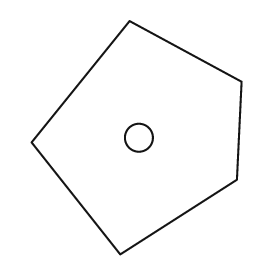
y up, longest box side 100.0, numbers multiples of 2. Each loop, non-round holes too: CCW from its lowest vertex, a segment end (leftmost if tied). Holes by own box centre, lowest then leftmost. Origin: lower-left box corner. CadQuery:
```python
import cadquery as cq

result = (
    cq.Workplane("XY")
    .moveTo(38.0, 0.0)
    .lineTo(88.0, 32.0)
    .lineTo(90.0, 74.0)
    .lineTo(42.0, 100.0)
    .lineTo(0.0, 48.0)
    .close()
    .moveTo(46.0, 50.0)
    .circle(6.0)
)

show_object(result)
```